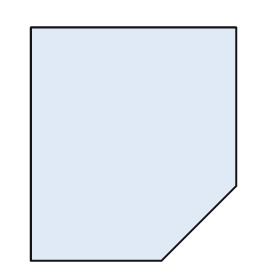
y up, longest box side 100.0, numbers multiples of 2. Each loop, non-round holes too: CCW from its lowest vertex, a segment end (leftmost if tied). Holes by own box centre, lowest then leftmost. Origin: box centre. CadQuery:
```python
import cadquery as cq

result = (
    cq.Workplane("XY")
    .moveTo(-44.0, -50.0)
    .lineTo(12.0, -50.0)
    .lineTo(44.0, -18.0)
    .lineTo(44.0, 50.0)
    .lineTo(-44.0, 50.0)
    .close()
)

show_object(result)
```